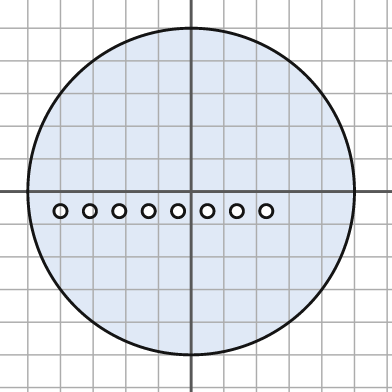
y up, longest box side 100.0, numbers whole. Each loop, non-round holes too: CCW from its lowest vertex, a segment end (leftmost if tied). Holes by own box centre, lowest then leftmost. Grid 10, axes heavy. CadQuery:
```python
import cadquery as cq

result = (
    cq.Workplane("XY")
    .moveTo(0.0, 0.0)
    .circle(50.0)
    .moveTo(-40.0, -6.0)
    .circle(2.0)
    .moveTo(-31.0, -6.0)
    .circle(2.0)
    .moveTo(-22.0, -6.0)
    .circle(2.0)
    .moveTo(-13.0, -6.0)
    .circle(2.0)
    .moveTo(-4.0, -6.0)
    .circle(2.0)
    .moveTo(5.0, -6.0)
    .circle(2.0)
    .moveTo(14.0, -6.0)
    .circle(2.0)
    .moveTo(23.0, -6.0)
    .circle(2.0)
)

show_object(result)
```